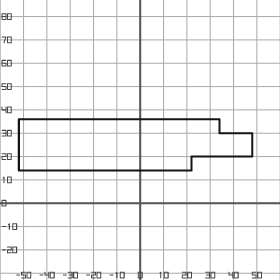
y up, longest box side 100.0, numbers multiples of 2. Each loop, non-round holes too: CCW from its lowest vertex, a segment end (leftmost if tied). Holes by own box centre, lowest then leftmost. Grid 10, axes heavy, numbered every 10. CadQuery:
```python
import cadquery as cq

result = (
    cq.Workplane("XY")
    .moveTo(-52.0, 14.0)
    .lineTo(22.0, 14.0)
    .lineTo(22.0, 20.0)
    .lineTo(48.0, 20.0)
    .lineTo(48.0, 30.0)
    .lineTo(34.0, 30.0)
    .lineTo(34.0, 36.0)
    .lineTo(-52.0, 36.0)
    .close()
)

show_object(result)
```